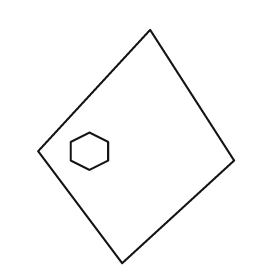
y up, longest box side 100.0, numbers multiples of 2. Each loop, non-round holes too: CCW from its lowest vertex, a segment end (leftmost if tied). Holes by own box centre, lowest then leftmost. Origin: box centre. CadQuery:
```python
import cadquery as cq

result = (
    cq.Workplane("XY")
    .moveTo(-6.0, -50.0)
    .lineTo(42.0, -6.0)
    .lineTo(6.0, 50.0)
    .lineTo(-42.0, -2.0)
    .close()
    .moveTo(-20.0, -10.0)
    .lineTo(-12.0, -6.0)
    .lineTo(-12.0, 2.0)
    .lineTo(-20.0, 6.0)
    .lineTo(-28.0, 2.0)
    .lineTo(-28.0, -6.0)
    .close()
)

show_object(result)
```